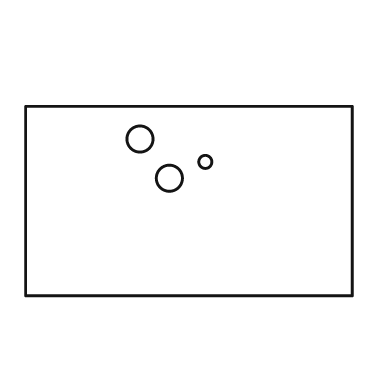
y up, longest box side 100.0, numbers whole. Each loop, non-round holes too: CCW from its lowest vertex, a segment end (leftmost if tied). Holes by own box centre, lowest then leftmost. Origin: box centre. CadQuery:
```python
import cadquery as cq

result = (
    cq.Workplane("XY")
    .moveTo(-50.0, -29.0)
    .lineTo(50.0, -29.0)
    .lineTo(50.0, 29.0)
    .lineTo(-50.0, 29.0)
    .close()
    .moveTo(-6.0, 7.0)
    .circle(4.0)
    .moveTo(5.0, 12.0)
    .circle(2.0)
    .moveTo(-15.0, 19.0)
    .circle(4.0)
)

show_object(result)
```